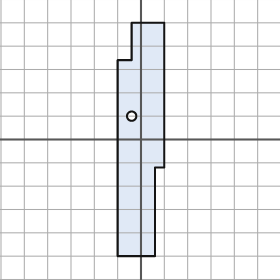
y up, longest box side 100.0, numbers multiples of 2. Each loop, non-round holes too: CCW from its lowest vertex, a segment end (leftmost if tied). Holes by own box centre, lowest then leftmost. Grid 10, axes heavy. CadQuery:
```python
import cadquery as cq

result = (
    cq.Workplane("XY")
    .moveTo(-10.0, -50.0)
    .lineTo(6.0, -50.0)
    .lineTo(6.0, -12.0)
    .lineTo(10.0, -12.0)
    .lineTo(10.0, 50.0)
    .lineTo(-4.0, 50.0)
    .lineTo(-4.0, 34.0)
    .lineTo(-10.0, 34.0)
    .close()
    .moveTo(-4.0, 10.0)
    .circle(2.0)
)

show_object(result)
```